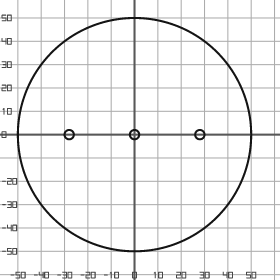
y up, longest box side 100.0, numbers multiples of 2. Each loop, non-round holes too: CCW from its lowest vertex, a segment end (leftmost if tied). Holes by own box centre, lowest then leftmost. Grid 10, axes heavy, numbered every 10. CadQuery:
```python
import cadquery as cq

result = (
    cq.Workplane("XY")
    .moveTo(0.0, 0.0)
    .circle(50.0)
    .moveTo(-28.0, 0.0)
    .circle(2.0)
    .moveTo(0.0, 0.0)
    .circle(2.0)
    .moveTo(28.0, 0.0)
    .circle(2.0)
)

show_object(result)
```